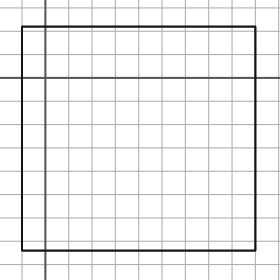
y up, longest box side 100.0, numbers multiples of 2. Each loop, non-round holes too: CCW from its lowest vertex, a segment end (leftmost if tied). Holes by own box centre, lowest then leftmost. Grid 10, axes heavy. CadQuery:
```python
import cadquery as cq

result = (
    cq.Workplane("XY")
    .moveTo(-10.0, -74.0)
    .lineTo(90.0, -74.0)
    .lineTo(90.0, 22.0)
    .lineTo(-10.0, 22.0)
    .close()
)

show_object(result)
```